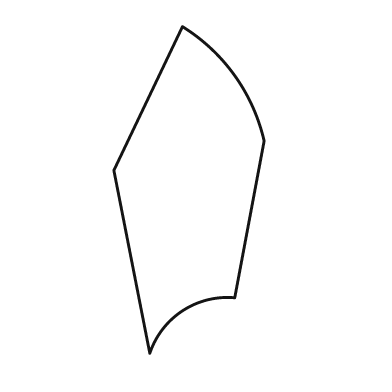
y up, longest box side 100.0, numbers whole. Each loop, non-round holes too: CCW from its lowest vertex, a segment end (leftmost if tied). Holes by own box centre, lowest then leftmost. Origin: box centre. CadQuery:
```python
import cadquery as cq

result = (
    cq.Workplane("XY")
    .moveTo(-12.0, -50.0)
    .threePointArc((-2.0, -37.0), (14.0, -33.0))
    .lineTo(23.0, 15.0)
    .threePointArc((14.0, 35.0), (-2.0, 50.0))
    .lineTo(-23.0, 6.0)
    .close()
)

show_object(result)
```